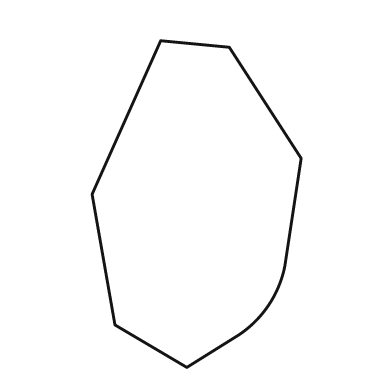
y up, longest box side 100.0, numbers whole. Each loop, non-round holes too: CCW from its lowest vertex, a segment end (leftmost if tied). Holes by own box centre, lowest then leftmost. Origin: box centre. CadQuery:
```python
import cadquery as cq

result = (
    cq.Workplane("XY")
    .moveTo(-3.0, -50.0)
    .lineTo(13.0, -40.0)
    .threePointArc((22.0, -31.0), (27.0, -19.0))
    .lineTo(32.0, 14.0)
    .lineTo(10.0, 48.0)
    .lineTo(-11.0, 50.0)
    .lineTo(-32.0, 3.0)
    .lineTo(-25.0, -37.0)
    .close()
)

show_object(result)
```